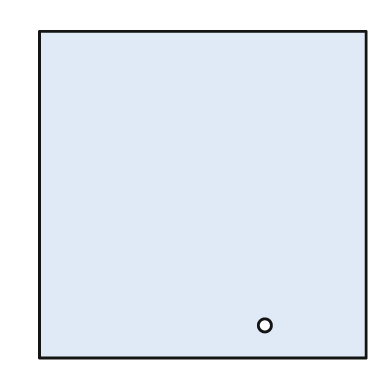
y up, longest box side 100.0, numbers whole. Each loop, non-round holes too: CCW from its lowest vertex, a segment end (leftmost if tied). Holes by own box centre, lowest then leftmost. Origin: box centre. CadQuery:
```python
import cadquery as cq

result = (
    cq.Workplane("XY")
    .moveTo(-50.0, -50.0)
    .lineTo(50.0, -50.0)
    .lineTo(50.0, 50.0)
    .lineTo(-50.0, 50.0)
    .close()
    .moveTo(19.0, -40.0)
    .circle(2.0)
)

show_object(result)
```